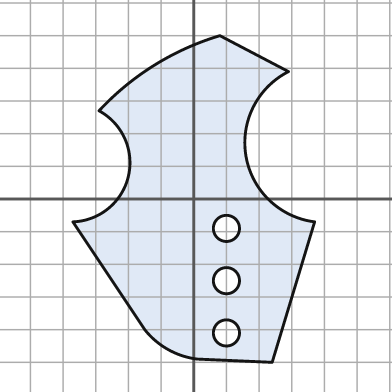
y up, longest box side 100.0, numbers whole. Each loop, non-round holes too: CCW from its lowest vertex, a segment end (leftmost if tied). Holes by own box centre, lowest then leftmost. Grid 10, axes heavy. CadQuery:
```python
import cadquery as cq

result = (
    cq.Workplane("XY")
    .moveTo(24.0, -50.0)
    .lineTo(37.0, -7.0)
    .threePointArc((16.0, 13.0), (29.0, 39.0))
    .lineTo(8.0, 50.0)
    .threePointArc((-12.0, 41.0), (-29.0, 27.0))
    .threePointArc((-20.0, 7.0), (-37.0, -7.0))
    .lineTo(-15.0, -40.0)
    .threePointArc((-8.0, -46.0), (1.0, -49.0))
    .close()
    .moveTo(10.0, -41.0)
    .circle(4.0)
    .moveTo(10.0, -25.0)
    .circle(4.0)
    .moveTo(10.0, -9.0)
    .circle(4.0)
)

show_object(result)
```